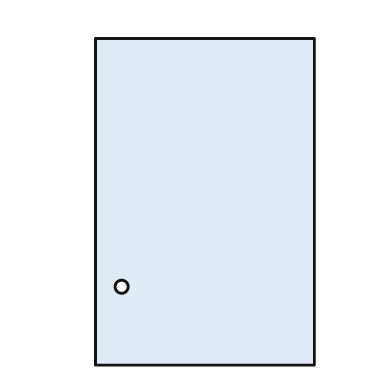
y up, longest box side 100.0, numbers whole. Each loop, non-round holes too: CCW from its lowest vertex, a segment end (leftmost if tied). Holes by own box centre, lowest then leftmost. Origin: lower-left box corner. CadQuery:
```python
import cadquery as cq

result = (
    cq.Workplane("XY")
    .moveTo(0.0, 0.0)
    .lineTo(67.0, 0.0)
    .lineTo(67.0, 100.0)
    .lineTo(0.0, 100.0)
    .close()
    .moveTo(8.0, 24.0)
    .circle(2.0)
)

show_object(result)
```